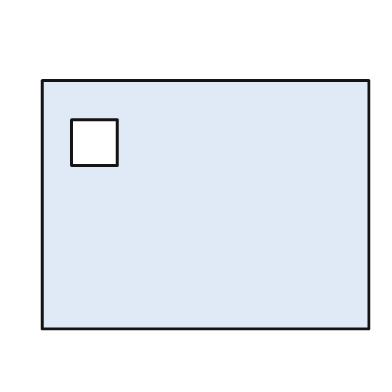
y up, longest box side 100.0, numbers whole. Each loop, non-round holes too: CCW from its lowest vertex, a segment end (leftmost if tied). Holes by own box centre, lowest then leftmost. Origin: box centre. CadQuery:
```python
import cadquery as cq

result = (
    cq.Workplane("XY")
    .moveTo(-50.0, -38.0)
    .lineTo(50.0, -38.0)
    .lineTo(50.0, 38.0)
    .lineTo(-50.0, 38.0)
    .close()
    .moveTo(-41.0, 12.0)
    .lineTo(-27.0, 12.0)
    .lineTo(-27.0, 26.0)
    .lineTo(-41.0, 26.0)
    .close()
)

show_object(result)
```